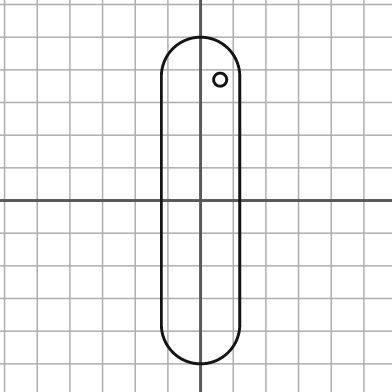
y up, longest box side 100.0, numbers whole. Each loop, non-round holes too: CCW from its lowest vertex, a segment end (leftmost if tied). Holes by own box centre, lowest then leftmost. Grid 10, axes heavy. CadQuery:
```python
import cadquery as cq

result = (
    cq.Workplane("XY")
    .moveTo(-12.0, -38.0)
    .threePointArc((0.0, -50.0), (12.0, -38.0))
    .lineTo(12.0, 38.0)
    .threePointArc((0.0, 50.0), (-12.0, 38.0))
    .close()
    .moveTo(6.0, 37.0)
    .circle(2.0)
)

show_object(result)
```